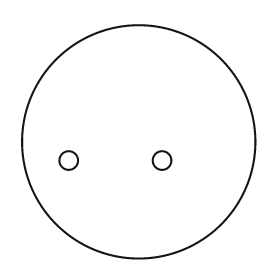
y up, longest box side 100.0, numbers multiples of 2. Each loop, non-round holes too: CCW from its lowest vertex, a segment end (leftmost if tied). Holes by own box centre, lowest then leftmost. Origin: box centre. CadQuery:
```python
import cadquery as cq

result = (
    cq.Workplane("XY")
    .moveTo(0.0, 0.0)
    .circle(50.0)
    .moveTo(-30.0, -8.0)
    .circle(4.0)
    .moveTo(10.0, -8.0)
    .circle(4.0)
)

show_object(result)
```